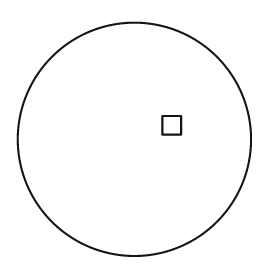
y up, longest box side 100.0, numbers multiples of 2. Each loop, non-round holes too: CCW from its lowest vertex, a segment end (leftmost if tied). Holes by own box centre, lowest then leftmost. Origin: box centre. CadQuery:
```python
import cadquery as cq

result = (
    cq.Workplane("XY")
    .moveTo(0.0, 0.0)
    .circle(50.0)
    .moveTo(12.0, 2.0)
    .lineTo(20.0, 2.0)
    .lineTo(20.0, 10.0)
    .lineTo(12.0, 10.0)
    .close()
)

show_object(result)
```